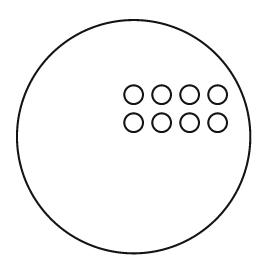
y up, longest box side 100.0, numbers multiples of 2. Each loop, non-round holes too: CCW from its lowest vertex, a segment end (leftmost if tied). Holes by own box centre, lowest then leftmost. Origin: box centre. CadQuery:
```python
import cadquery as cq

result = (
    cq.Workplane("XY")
    .moveTo(0.0, 0.0)
    .circle(50.0)
    .moveTo(0.0, 6.0)
    .circle(4.0)
    .moveTo(12.0, 6.0)
    .circle(4.0)
    .moveTo(24.0, 6.0)
    .circle(4.0)
    .moveTo(36.0, 6.0)
    .circle(4.0)
    .moveTo(0.0, 18.0)
    .circle(4.0)
    .moveTo(12.0, 18.0)
    .circle(4.0)
    .moveTo(24.0, 18.0)
    .circle(4.0)
    .moveTo(36.0, 18.0)
    .circle(4.0)
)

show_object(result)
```